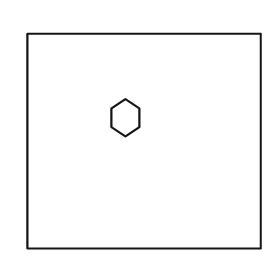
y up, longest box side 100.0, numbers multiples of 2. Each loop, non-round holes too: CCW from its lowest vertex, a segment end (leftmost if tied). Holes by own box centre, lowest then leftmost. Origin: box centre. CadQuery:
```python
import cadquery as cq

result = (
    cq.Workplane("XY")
    .moveTo(-50.0, -46.0)
    .lineTo(50.0, -46.0)
    .lineTo(50.0, 46.0)
    .lineTo(-50.0, 46.0)
    .close()
    .moveTo(-8.0, 2.0)
    .lineTo(-2.0, 6.0)
    .lineTo(-2.0, 14.0)
    .lineTo(-8.0, 18.0)
    .lineTo(-14.0, 14.0)
    .lineTo(-14.0, 6.0)
    .close()
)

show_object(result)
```